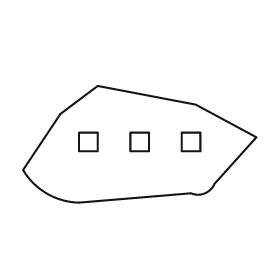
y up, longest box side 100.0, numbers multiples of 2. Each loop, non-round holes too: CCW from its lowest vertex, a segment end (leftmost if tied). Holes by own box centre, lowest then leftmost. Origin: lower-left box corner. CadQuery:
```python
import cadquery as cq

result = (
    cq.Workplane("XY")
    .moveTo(24.0, 0.0)
    .lineTo(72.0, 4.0)
    .threePointArc((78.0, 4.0), (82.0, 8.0))
    .lineTo(100.0, 28.0)
    .lineTo(74.0, 42.0)
    .lineTo(32.0, 50.0)
    .lineTo(16.0, 38.0)
    .lineTo(0.0, 14.0)
    .threePointArc((10.0, 4.0), (24.0, 0.0))
    .close()
    .moveTo(24.0, 22.0)
    .lineTo(32.0, 22.0)
    .lineTo(32.0, 30.0)
    .lineTo(24.0, 30.0)
    .close()
    .moveTo(46.0, 22.0)
    .lineTo(54.0, 22.0)
    .lineTo(54.0, 30.0)
    .lineTo(46.0, 30.0)
    .close()
    .moveTo(68.0, 22.0)
    .lineTo(76.0, 22.0)
    .lineTo(76.0, 30.0)
    .lineTo(68.0, 30.0)
    .close()
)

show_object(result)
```